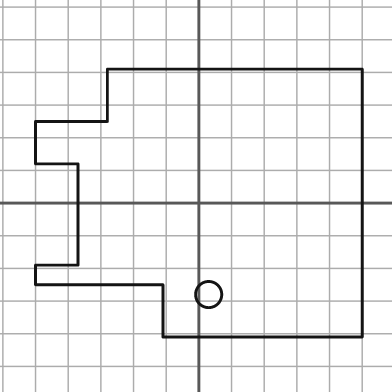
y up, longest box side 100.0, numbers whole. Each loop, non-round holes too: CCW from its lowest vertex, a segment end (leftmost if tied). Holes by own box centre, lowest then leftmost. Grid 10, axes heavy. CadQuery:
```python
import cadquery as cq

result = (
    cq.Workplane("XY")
    .moveTo(-11.0, -41.0)
    .lineTo(50.0, -41.0)
    .lineTo(50.0, 41.0)
    .lineTo(-28.0, 41.0)
    .lineTo(-28.0, 25.0)
    .lineTo(-50.0, 25.0)
    .lineTo(-50.0, 12.0)
    .lineTo(-37.0, 12.0)
    .lineTo(-37.0, -19.0)
    .lineTo(-50.0, -19.0)
    .lineTo(-50.0, -25.0)
    .lineTo(-11.0, -25.0)
    .close()
    .moveTo(3.0, -28.0)
    .circle(4.0)
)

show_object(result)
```